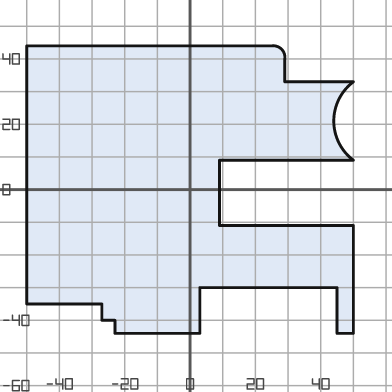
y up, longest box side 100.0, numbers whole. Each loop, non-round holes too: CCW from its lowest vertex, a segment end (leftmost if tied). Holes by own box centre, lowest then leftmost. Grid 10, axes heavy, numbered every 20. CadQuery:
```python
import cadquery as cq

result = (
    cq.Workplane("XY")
    .moveTo(-23.0, -44.0)
    .lineTo(3.0, -44.0)
    .lineTo(3.0, -30.0)
    .lineTo(45.0, -30.0)
    .lineTo(45.0, -44.0)
    .lineTo(50.0, -44.0)
    .lineTo(50.0, -11.0)
    .lineTo(9.0, -11.0)
    .lineTo(9.0, 9.0)
    .lineTo(50.0, 9.0)
    .threePointArc((44.0, 21.0), (50.0, 33.0))
    .lineTo(29.0, 33.0)
    .lineTo(29.0, 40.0)
    .threePointArc((28.0, 43.0), (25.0, 44.0))
    .lineTo(-50.0, 44.0)
    .lineTo(-50.0, -35.0)
    .lineTo(-27.0, -35.0)
    .lineTo(-27.0, -40.0)
    .lineTo(-23.0, -40.0)
    .close()
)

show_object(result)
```